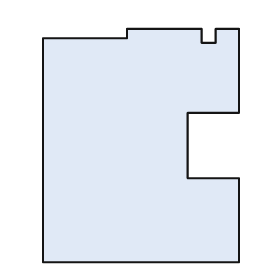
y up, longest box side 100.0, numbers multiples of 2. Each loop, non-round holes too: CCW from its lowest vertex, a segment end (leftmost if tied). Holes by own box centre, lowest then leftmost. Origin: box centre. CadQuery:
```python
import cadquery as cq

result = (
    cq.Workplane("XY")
    .moveTo(-42.0, -50.0)
    .lineTo(42.0, -50.0)
    .lineTo(42.0, -14.0)
    .lineTo(20.0, -14.0)
    .lineTo(20.0, 14.0)
    .lineTo(42.0, 14.0)
    .lineTo(42.0, 50.0)
    .lineTo(32.0, 50.0)
    .lineTo(32.0, 44.0)
    .lineTo(26.0, 44.0)
    .lineTo(26.0, 50.0)
    .lineTo(-6.0, 50.0)
    .lineTo(-6.0, 46.0)
    .lineTo(-42.0, 46.0)
    .close()
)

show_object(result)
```